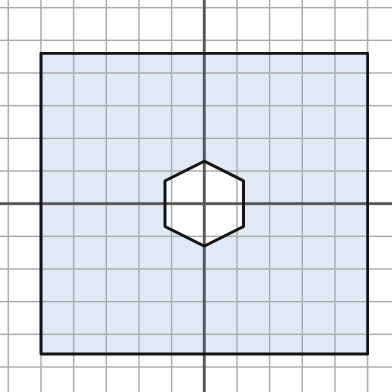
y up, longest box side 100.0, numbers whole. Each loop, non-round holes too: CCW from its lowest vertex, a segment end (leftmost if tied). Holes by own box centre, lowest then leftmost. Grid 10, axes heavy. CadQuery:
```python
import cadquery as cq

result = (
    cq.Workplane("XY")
    .moveTo(-50.0, -46.0)
    .lineTo(50.0, -46.0)
    .lineTo(50.0, 46.0)
    .lineTo(-50.0, 46.0)
    .close()
    .moveTo(0.0, -13.0)
    .lineTo(12.0, -7.0)
    .lineTo(12.0, 7.0)
    .lineTo(0.0, 13.0)
    .lineTo(-12.0, 7.0)
    .lineTo(-12.0, -7.0)
    .close()
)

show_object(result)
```